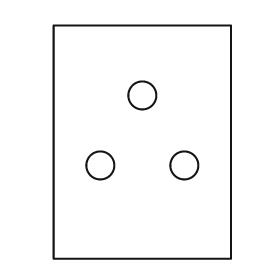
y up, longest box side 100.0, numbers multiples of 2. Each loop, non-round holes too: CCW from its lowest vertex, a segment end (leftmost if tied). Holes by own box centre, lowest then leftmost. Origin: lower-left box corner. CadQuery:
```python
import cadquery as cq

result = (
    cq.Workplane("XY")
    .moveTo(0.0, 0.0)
    .lineTo(76.0, 0.0)
    .lineTo(76.0, 100.0)
    .lineTo(0.0, 100.0)
    .close()
    .moveTo(20.0, 40.0)
    .circle(6.0)
    .moveTo(56.0, 40.0)
    .circle(6.0)
    .moveTo(38.0, 70.0)
    .circle(6.0)
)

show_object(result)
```